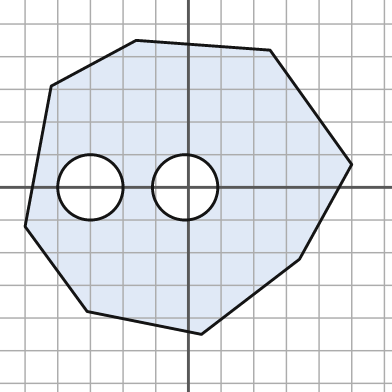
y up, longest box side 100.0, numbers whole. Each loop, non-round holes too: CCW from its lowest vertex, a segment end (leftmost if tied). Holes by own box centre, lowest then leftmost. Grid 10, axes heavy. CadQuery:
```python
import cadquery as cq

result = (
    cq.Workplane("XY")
    .moveTo(4.0, -45.0)
    .lineTo(34.0, -22.0)
    .lineTo(50.0, 7.0)
    .lineTo(25.0, 42.0)
    .lineTo(-16.0, 45.0)
    .lineTo(-42.0, 31.0)
    .lineTo(-50.0, -12.0)
    .lineTo(-31.0, -38.0)
    .close()
    .moveTo(-30.0, 0.0)
    .circle(10.0)
    .moveTo(-1.0, 0.0)
    .circle(10.0)
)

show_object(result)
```